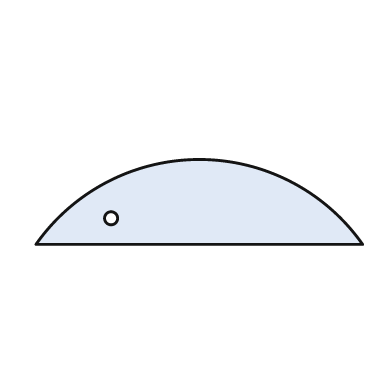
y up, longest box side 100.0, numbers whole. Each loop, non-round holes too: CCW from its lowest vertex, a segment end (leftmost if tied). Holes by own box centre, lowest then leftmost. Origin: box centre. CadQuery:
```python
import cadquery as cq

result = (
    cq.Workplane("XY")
    .moveTo(-50.0, -13.0)
    .lineTo(50.0, -13.0)
    .threePointArc((0.0, 13.0), (-50.0, -13.0))
    .close()
    .moveTo(-27.0, -5.0)
    .circle(2.0)
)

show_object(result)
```